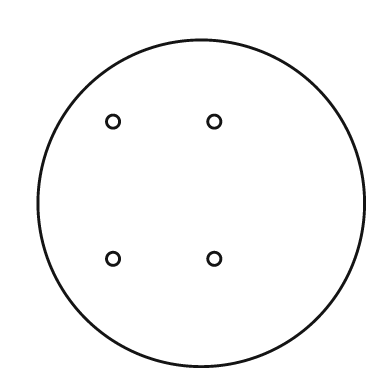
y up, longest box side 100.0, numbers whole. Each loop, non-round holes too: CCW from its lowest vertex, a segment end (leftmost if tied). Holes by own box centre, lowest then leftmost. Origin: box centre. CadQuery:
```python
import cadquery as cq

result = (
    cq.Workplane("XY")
    .moveTo(0.0, 0.0)
    .circle(50.0)
    .moveTo(-27.0, -17.0)
    .circle(2.0)
    .moveTo(4.0, -17.0)
    .circle(2.0)
    .moveTo(-27.0, 25.0)
    .circle(2.0)
    .moveTo(4.0, 25.0)
    .circle(2.0)
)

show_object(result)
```